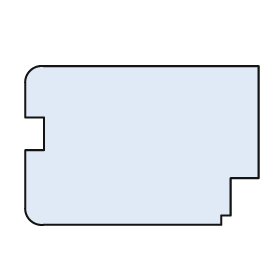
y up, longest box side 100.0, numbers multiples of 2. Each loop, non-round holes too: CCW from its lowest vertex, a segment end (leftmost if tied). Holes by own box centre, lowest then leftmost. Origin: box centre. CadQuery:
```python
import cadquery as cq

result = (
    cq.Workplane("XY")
    .moveTo(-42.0, -34.0)
    .lineTo(34.0, -34.0)
    .lineTo(34.0, -30.0)
    .lineTo(38.0, -30.0)
    .lineTo(38.0, -14.0)
    .lineTo(50.0, -14.0)
    .lineTo(50.0, 34.0)
    .lineTo(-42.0, 34.0)
    .threePointArc((-48.0, 32.0), (-50.0, 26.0))
    .lineTo(-50.0, 12.0)
    .lineTo(-42.0, 12.0)
    .lineTo(-42.0, -2.0)
    .lineTo(-50.0, -2.0)
    .lineTo(-50.0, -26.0)
    .threePointArc((-48.0, -32.0), (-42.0, -34.0))
    .close()
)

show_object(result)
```